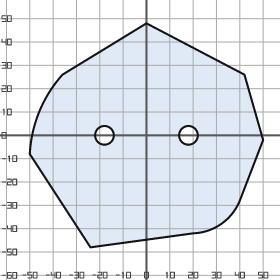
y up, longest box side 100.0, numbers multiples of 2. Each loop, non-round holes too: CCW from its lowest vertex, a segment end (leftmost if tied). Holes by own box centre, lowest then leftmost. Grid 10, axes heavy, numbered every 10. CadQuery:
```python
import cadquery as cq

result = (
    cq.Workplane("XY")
    .moveTo(-24.0, -48.0)
    .lineTo(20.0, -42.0)
    .threePointArc((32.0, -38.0), (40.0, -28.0))
    .lineTo(50.0, -2.0)
    .lineTo(42.0, 26.0)
    .lineTo(0.0, 48.0)
    .lineTo(-36.0, 26.0)
    .threePointArc((-46.0, 10.0), (-50.0, -8.0))
    .close()
    .moveTo(-18.0, 0.0)
    .circle(4.0)
    .moveTo(18.0, 0.0)
    .circle(4.0)
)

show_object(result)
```